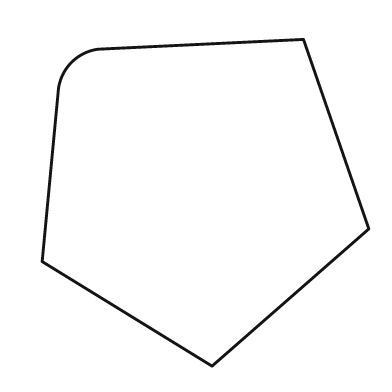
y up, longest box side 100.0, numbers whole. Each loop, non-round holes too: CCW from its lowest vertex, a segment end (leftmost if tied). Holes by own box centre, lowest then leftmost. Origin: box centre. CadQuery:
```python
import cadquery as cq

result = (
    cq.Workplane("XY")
    .moveTo(2.0, -50.0)
    .lineTo(50.0, -8.0)
    .lineTo(30.0, 50.0)
    .lineTo(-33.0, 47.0)
    .threePointArc((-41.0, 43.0), (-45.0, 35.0))
    .lineTo(-50.0, -18.0)
    .close()
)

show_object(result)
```